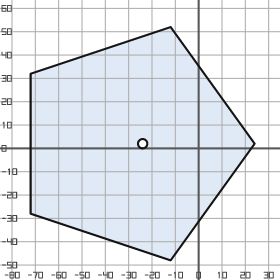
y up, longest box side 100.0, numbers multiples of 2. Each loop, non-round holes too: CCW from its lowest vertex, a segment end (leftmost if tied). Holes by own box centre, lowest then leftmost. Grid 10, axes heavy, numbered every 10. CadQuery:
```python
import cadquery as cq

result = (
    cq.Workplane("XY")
    .moveTo(-12.0, -48.0)
    .lineTo(24.0, 2.0)
    .lineTo(-12.0, 52.0)
    .lineTo(-72.0, 32.0)
    .lineTo(-72.0, -28.0)
    .close()
    .moveTo(-24.0, 2.0)
    .circle(2.0)
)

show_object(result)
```